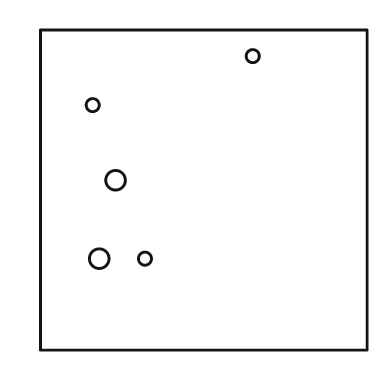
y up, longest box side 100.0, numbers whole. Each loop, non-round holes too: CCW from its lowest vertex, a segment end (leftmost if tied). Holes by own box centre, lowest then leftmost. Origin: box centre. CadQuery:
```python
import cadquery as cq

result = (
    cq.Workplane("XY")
    .moveTo(-50.0, -49.0)
    .lineTo(50.0, -49.0)
    .lineTo(50.0, 49.0)
    .lineTo(-50.0, 49.0)
    .close()
    .moveTo(-32.0, -21.0)
    .circle(3.0)
    .moveTo(-18.0, -21.0)
    .circle(2.0)
    .moveTo(-27.0, 3.0)
    .circle(3.0)
    .moveTo(-34.0, 26.0)
    .circle(2.0)
    .moveTo(15.0, 41.0)
    .circle(2.0)
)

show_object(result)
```